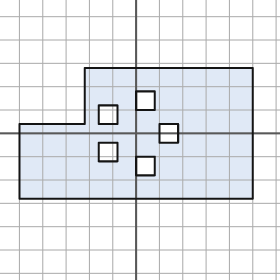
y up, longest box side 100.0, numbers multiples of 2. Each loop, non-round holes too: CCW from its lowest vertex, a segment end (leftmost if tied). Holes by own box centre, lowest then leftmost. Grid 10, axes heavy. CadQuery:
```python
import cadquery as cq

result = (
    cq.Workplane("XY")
    .moveTo(-50.0, -28.0)
    .lineTo(50.0, -28.0)
    .lineTo(50.0, 28.0)
    .lineTo(-22.0, 28.0)
    .lineTo(-22.0, 4.0)
    .lineTo(-50.0, 4.0)
    .close()
    .moveTo(0.0, -18.0)
    .lineTo(8.0, -18.0)
    .lineTo(8.0, -10.0)
    .lineTo(0.0, -10.0)
    .close()
    .moveTo(-16.0, -12.0)
    .lineTo(-8.0, -12.0)
    .lineTo(-8.0, -4.0)
    .lineTo(-16.0, -4.0)
    .close()
    .moveTo(10.0, -4.0)
    .lineTo(18.0, -4.0)
    .lineTo(18.0, 4.0)
    .lineTo(10.0, 4.0)
    .close()
    .moveTo(-16.0, 4.0)
    .lineTo(-8.0, 4.0)
    .lineTo(-8.0, 12.0)
    .lineTo(-16.0, 12.0)
    .close()
    .moveTo(0.0, 10.0)
    .lineTo(8.0, 10.0)
    .lineTo(8.0, 18.0)
    .lineTo(0.0, 18.0)
    .close()
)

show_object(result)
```